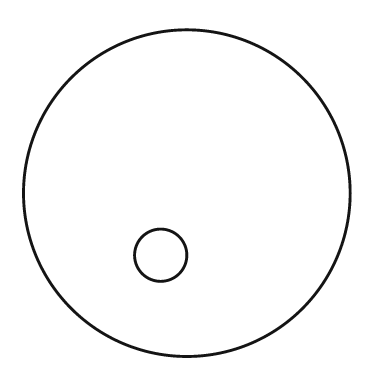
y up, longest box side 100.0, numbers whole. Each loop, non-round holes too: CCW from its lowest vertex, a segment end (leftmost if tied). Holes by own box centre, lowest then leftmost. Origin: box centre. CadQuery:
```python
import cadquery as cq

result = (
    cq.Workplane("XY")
    .moveTo(0.0, 0.0)
    .circle(50.0)
    .moveTo(-8.0, -19.0)
    .circle(8.0)
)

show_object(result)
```